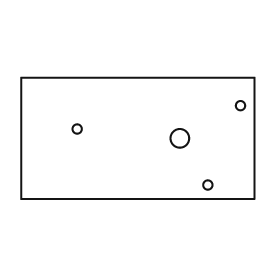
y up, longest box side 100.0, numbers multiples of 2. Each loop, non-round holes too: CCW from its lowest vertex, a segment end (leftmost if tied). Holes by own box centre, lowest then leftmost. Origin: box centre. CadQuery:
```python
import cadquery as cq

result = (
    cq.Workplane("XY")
    .moveTo(-50.0, -26.0)
    .lineTo(50.0, -26.0)
    .lineTo(50.0, 26.0)
    .lineTo(-50.0, 26.0)
    .close()
    .moveTo(30.0, -20.0)
    .circle(2.0)
    .moveTo(18.0, 0.0)
    .circle(4.0)
    .moveTo(-26.0, 4.0)
    .circle(2.0)
    .moveTo(44.0, 14.0)
    .circle(2.0)
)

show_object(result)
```